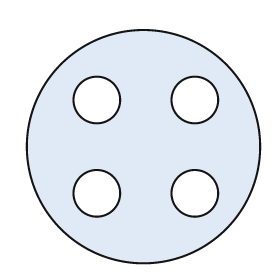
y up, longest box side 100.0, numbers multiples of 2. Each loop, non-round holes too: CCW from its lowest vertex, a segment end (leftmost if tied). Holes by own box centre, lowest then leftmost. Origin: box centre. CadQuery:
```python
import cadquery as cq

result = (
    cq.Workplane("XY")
    .moveTo(0.0, 0.0)
    .circle(50.0)
    .moveTo(-20.0, -20.0)
    .circle(10.0)
    .moveTo(22.0, -20.0)
    .circle(10.0)
    .moveTo(-20.0, 20.0)
    .circle(10.0)
    .moveTo(22.0, 20.0)
    .circle(10.0)
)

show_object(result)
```